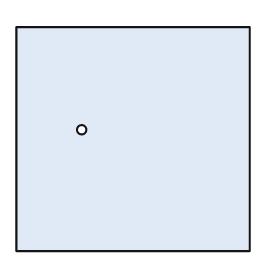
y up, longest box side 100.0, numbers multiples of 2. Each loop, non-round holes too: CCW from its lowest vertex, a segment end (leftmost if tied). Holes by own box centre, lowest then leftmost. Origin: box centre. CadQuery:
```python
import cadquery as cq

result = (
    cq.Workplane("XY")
    .moveTo(-50.0, -48.0)
    .lineTo(50.0, -48.0)
    .lineTo(50.0, 48.0)
    .lineTo(-50.0, 48.0)
    .close()
    .moveTo(-22.0, 4.0)
    .circle(2.0)
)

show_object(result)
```